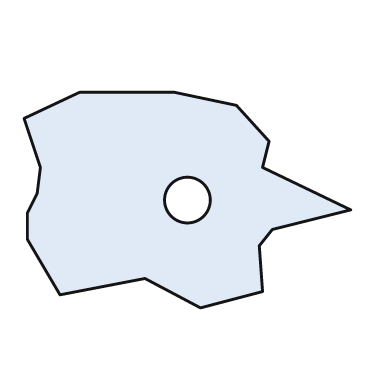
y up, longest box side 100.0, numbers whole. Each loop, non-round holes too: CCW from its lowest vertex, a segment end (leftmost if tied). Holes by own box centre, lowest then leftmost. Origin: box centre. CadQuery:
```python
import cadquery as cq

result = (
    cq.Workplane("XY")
    .moveTo(4.0, -33.0)
    .lineTo(23.0, -28.0)
    .lineTo(22.0, -14.0)
    .lineTo(26.0, -9.0)
    .lineTo(50.0, -3.0)
    .lineTo(23.0, 10.0)
    .lineTo(25.0, 18.0)
    .lineTo(15.0, 29.0)
    .lineTo(-4.0, 33.0)
    .lineTo(-33.0, 33.0)
    .lineTo(-50.0, 25.0)
    .lineTo(-45.0, 10.0)
    .lineTo(-46.0, 2.0)
    .lineTo(-49.0, -4.0)
    .lineTo(-49.0, -12.0)
    .lineTo(-39.0, -29.0)
    .lineTo(-13.0, -24.0)
    .close()
    .moveTo(0.0, 0.0)
    .circle(7.0)
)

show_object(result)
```